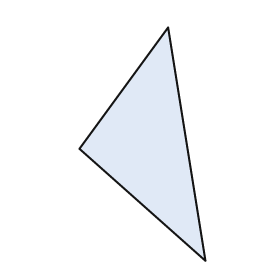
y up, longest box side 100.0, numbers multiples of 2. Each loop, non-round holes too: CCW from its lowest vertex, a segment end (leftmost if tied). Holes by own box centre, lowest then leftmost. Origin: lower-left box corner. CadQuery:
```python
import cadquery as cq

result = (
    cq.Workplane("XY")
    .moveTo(54.0, 0.0)
    .lineTo(38.0, 100.0)
    .lineTo(0.0, 48.0)
    .close()
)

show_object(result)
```